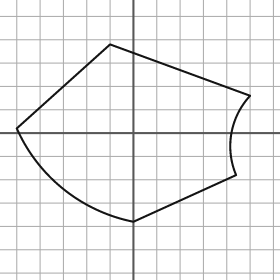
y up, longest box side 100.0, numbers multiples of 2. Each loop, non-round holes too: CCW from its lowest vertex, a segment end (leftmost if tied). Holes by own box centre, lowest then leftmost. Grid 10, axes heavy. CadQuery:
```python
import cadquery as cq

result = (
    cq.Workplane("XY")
    .moveTo(0.0, -38.0)
    .lineTo(44.0, -18.0)
    .threePointArc((42.0, 0.0), (50.0, 16.0))
    .lineTo(-10.0, 38.0)
    .lineTo(-50.0, 2.0)
    .threePointArc((-30.0, -24.0), (0.0, -38.0))
    .close()
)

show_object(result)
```